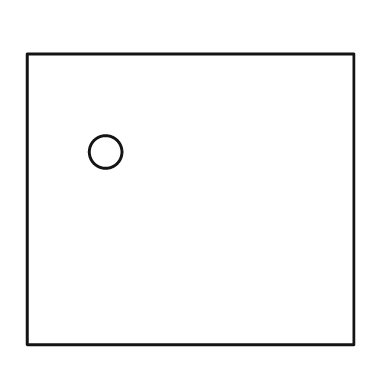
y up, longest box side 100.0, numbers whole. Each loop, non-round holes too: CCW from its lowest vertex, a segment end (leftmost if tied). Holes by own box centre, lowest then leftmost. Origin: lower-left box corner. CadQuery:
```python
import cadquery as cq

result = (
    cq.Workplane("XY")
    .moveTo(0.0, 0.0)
    .lineTo(100.0, 0.0)
    .lineTo(100.0, 89.0)
    .lineTo(0.0, 89.0)
    .close()
    .moveTo(24.0, 59.0)
    .circle(5.0)
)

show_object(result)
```